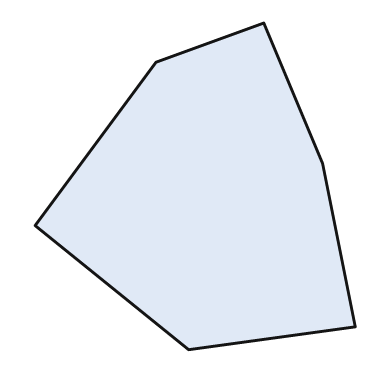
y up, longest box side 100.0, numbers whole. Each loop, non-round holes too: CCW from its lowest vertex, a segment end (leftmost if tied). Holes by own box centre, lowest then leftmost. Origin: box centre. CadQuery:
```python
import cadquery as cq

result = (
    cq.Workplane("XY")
    .moveTo(-2.0, -50.0)
    .lineTo(49.0, -43.0)
    .lineTo(39.0, 7.0)
    .lineTo(21.0, 50.0)
    .lineTo(-12.0, 38.0)
    .lineTo(-49.0, -12.0)
    .close()
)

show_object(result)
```